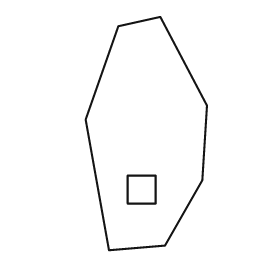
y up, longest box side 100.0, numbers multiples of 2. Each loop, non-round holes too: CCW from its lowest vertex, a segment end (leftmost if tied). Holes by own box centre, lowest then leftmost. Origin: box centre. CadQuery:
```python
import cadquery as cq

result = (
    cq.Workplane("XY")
    .moveTo(-16.0, -50.0)
    .lineTo(8.0, -48.0)
    .lineTo(24.0, -20.0)
    .lineTo(26.0, 12.0)
    .lineTo(6.0, 50.0)
    .lineTo(-12.0, 46.0)
    .lineTo(-26.0, 6.0)
    .close()
    .moveTo(-8.0, -30.0)
    .lineTo(4.0, -30.0)
    .lineTo(4.0, -18.0)
    .lineTo(-8.0, -18.0)
    .close()
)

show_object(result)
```